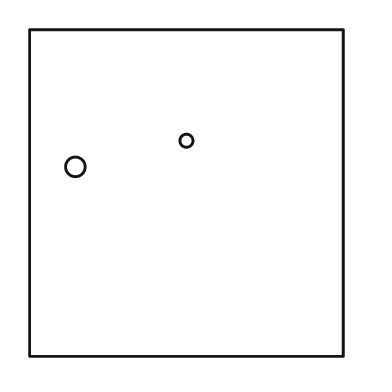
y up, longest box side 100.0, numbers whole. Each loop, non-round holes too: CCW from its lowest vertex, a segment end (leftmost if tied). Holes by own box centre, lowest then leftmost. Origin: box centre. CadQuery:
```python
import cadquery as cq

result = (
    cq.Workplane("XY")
    .moveTo(-48.0, -50.0)
    .lineTo(48.0, -50.0)
    .lineTo(48.0, 50.0)
    .lineTo(-48.0, 50.0)
    .close()
    .moveTo(-34.0, 8.0)
    .circle(3.0)
    .moveTo(0.0, 16.0)
    .circle(2.0)
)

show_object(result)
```